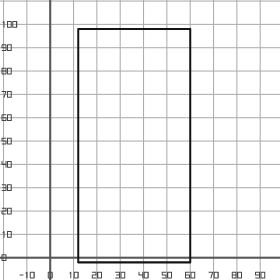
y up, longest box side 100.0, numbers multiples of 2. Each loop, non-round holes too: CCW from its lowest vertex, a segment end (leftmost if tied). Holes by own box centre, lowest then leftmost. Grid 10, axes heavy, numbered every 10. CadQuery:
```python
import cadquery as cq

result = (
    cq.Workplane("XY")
    .moveTo(12.0, -2.0)
    .lineTo(60.0, -2.0)
    .lineTo(60.0, 98.0)
    .lineTo(12.0, 98.0)
    .close()
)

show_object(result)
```